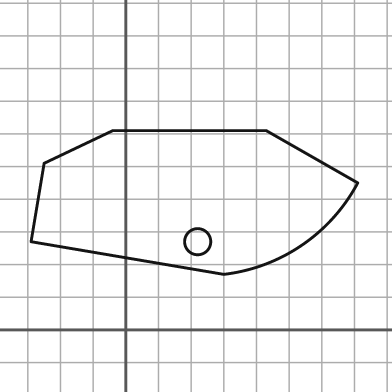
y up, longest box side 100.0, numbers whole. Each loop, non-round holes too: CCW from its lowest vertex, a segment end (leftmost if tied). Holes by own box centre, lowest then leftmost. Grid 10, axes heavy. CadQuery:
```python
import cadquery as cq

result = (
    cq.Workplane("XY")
    .moveTo(30.0, 17.0)
    .threePointArc((54.0, 26.0), (71.0, 45.0))
    .lineTo(43.0, 61.0)
    .lineTo(-4.0, 61.0)
    .lineTo(-25.0, 51.0)
    .lineTo(-29.0, 27.0)
    .close()
    .moveTo(22.0, 27.0)
    .circle(4.0)
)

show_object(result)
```